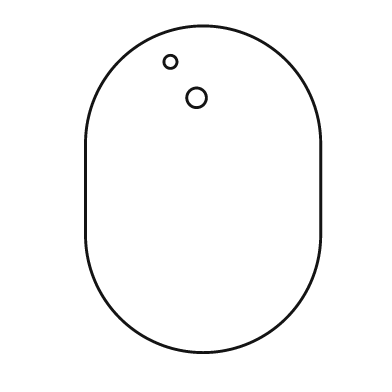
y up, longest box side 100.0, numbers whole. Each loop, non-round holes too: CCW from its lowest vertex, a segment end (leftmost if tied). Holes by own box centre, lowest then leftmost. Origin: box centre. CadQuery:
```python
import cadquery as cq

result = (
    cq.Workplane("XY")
    .moveTo(-36.0, -14.0)
    .threePointArc((0.0, -50.0), (36.0, -14.0))
    .lineTo(36.0, 14.0)
    .threePointArc((0.0, 50.0), (-36.0, 14.0))
    .close()
    .moveTo(-2.0, 28.0)
    .circle(3.0)
    .moveTo(-10.0, 39.0)
    .circle(2.0)
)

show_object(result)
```